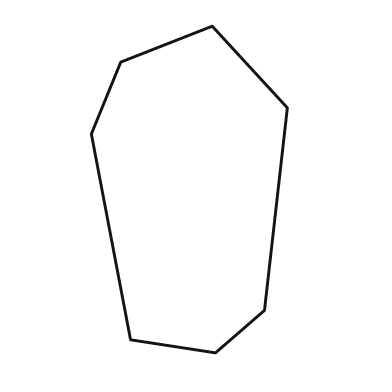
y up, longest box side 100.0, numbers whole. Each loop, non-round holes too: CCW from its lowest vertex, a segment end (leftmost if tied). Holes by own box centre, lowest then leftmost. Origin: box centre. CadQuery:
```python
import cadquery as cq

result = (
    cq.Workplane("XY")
    .moveTo(8.0, -50.0)
    .lineTo(23.0, -37.0)
    .lineTo(30.0, 25.0)
    .lineTo(7.0, 50.0)
    .lineTo(-21.0, 39.0)
    .lineTo(-30.0, 17.0)
    .lineTo(-18.0, -46.0)
    .close()
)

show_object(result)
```